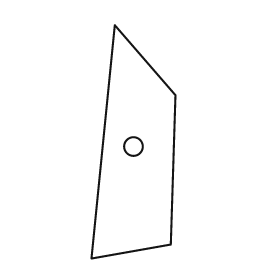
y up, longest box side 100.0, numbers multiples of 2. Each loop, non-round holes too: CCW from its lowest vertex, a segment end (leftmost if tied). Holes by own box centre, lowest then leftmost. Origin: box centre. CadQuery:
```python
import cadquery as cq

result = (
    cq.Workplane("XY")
    .moveTo(-18.0, -50.0)
    .lineTo(16.0, -44.0)
    .lineTo(18.0, 20.0)
    .lineTo(-8.0, 50.0)
    .close()
    .moveTo(0.0, -2.0)
    .circle(4.0)
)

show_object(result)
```